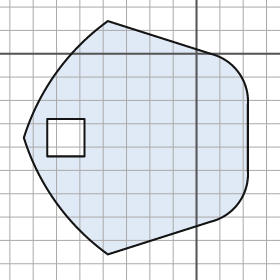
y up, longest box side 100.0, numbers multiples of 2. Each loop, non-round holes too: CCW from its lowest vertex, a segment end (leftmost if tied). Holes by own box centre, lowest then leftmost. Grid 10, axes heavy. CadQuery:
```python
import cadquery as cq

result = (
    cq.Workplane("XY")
    .moveTo(-38.0, -86.0)
    .lineTo(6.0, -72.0)
    .threePointArc((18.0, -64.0), (22.0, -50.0))
    .lineTo(22.0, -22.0)
    .threePointArc((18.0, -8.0), (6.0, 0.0))
    .lineTo(-38.0, 14.0)
    .threePointArc((-60.0, -8.0), (-74.0, -36.0))
    .threePointArc((-60.0, -64.0), (-38.0, -86.0))
    .close()
    .moveTo(-64.0, -44.0)
    .lineTo(-48.0, -44.0)
    .lineTo(-48.0, -28.0)
    .lineTo(-64.0, -28.0)
    .close()
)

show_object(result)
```